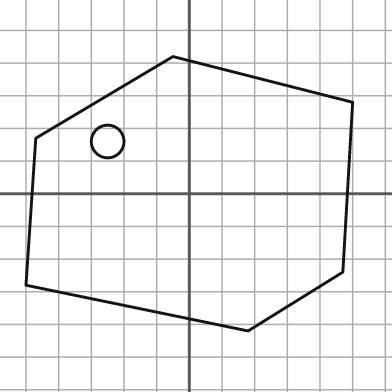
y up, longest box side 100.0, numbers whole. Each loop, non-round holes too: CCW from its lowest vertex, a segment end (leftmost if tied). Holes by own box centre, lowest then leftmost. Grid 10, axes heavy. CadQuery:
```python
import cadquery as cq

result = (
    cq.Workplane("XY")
    .moveTo(18.0, -42.0)
    .lineTo(47.0, -24.0)
    .lineTo(50.0, 28.0)
    .lineTo(-5.0, 42.0)
    .lineTo(-47.0, 17.0)
    .lineTo(-50.0, -28.0)
    .close()
    .moveTo(-25.0, 16.0)
    .circle(5.0)
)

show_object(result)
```